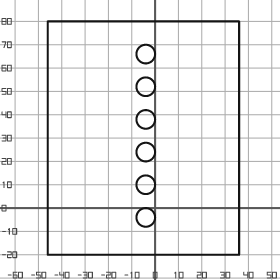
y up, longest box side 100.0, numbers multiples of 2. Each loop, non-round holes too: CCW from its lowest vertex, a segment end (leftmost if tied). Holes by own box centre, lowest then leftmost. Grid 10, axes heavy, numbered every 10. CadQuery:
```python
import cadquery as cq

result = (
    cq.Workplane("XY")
    .moveTo(-46.0, -20.0)
    .lineTo(36.0, -20.0)
    .lineTo(36.0, 80.0)
    .lineTo(-46.0, 80.0)
    .close()
    .moveTo(-4.0, -4.0)
    .circle(4.0)
    .moveTo(-4.0, 10.0)
    .circle(4.0)
    .moveTo(-4.0, 24.0)
    .circle(4.0)
    .moveTo(-4.0, 38.0)
    .circle(4.0)
    .moveTo(-4.0, 52.0)
    .circle(4.0)
    .moveTo(-4.0, 66.0)
    .circle(4.0)
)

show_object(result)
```